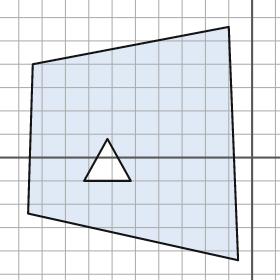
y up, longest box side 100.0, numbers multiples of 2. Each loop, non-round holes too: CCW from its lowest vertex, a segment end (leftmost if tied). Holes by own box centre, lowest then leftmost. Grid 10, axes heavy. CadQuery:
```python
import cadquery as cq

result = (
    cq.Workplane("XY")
    .moveTo(-6.0, -44.0)
    .lineTo(-10.0, 56.0)
    .lineTo(-94.0, 40.0)
    .lineTo(-96.0, -24.0)
    .close()
    .moveTo(-72.0, -10.0)
    .lineTo(-52.0, -10.0)
    .lineTo(-62.0, 8.0)
    .close()
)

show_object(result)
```